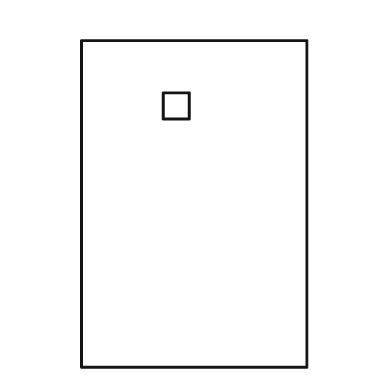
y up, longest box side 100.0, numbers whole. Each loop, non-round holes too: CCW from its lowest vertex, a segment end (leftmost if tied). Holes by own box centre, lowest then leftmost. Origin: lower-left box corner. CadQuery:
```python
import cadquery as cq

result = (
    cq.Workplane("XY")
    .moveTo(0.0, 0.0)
    .lineTo(69.0, 0.0)
    .lineTo(69.0, 100.0)
    .lineTo(0.0, 100.0)
    .close()
    .moveTo(25.0, 76.0)
    .lineTo(33.0, 76.0)
    .lineTo(33.0, 84.0)
    .lineTo(25.0, 84.0)
    .close()
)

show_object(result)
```